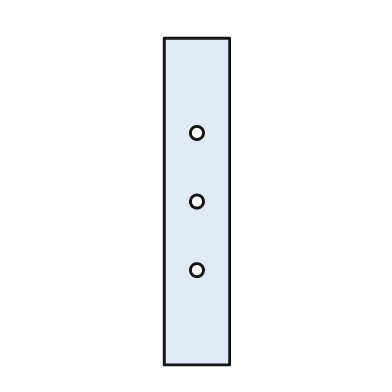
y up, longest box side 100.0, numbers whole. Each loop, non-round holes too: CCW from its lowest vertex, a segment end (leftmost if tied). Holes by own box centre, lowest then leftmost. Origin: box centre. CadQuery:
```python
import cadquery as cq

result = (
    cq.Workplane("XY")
    .moveTo(-10.0, -50.0)
    .lineTo(10.0, -50.0)
    .lineTo(10.0, 50.0)
    .lineTo(-10.0, 50.0)
    .close()
    .moveTo(0.0, -21.0)
    .circle(2.0)
    .moveTo(0.0, 0.0)
    .circle(2.0)
    .moveTo(0.0, 21.0)
    .circle(2.0)
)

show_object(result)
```